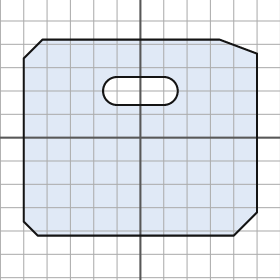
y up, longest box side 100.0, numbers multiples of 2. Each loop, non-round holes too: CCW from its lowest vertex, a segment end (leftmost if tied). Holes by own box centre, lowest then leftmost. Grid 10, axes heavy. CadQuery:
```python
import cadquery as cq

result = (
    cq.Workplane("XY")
    .moveTo(-44.0, -42.0)
    .lineTo(40.0, -42.0)
    .lineTo(50.0, -32.0)
    .lineTo(50.0, 36.0)
    .lineTo(34.0, 42.0)
    .lineTo(-42.0, 42.0)
    .lineTo(-50.0, 34.0)
    .lineTo(-50.0, -36.0)
    .close()
    .moveTo(-10.0, 14.0)
    .lineTo(10.0, 14.0)
    .threePointArc((16.0, 20.0), (10.0, 26.0))
    .lineTo(-10.0, 26.0)
    .threePointArc((-16.0, 20.0), (-10.0, 14.0))
    .close()
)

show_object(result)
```